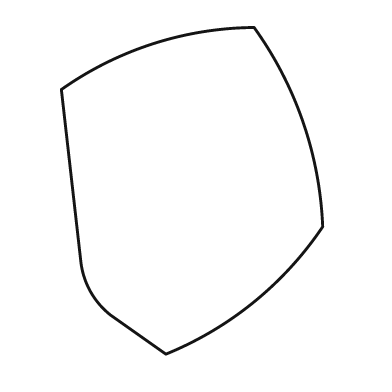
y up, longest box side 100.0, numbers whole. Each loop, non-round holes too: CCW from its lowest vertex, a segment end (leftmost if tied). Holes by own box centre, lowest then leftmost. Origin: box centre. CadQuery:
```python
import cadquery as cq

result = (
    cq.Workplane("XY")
    .moveTo(-8.0, -50.0)
    .threePointArc((19.0, -34.0), (40.0, -11.0))
    .threePointArc((34.0, 21.0), (19.0, 50.0))
    .threePointArc((-12.0, 45.0), (-40.0, 31.0))
    .lineTo(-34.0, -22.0)
    .threePointArc((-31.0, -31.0), (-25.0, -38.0))
    .close()
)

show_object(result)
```